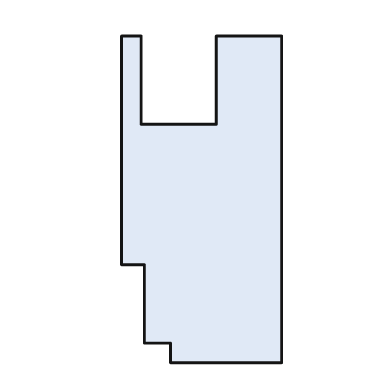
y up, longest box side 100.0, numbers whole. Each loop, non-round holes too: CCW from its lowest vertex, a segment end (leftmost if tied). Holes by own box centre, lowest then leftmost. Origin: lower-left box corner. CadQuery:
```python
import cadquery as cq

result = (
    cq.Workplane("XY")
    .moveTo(15.0, 0.0)
    .lineTo(49.0, 0.0)
    .lineTo(49.0, 100.0)
    .lineTo(29.0, 100.0)
    .lineTo(29.0, 73.0)
    .lineTo(6.0, 73.0)
    .lineTo(6.0, 100.0)
    .lineTo(0.0, 100.0)
    .lineTo(0.0, 30.0)
    .lineTo(7.0, 30.0)
    .lineTo(7.0, 6.0)
    .lineTo(15.0, 6.0)
    .close()
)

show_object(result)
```